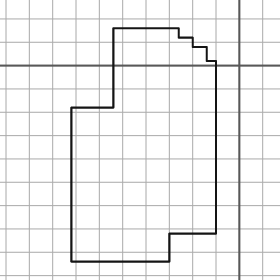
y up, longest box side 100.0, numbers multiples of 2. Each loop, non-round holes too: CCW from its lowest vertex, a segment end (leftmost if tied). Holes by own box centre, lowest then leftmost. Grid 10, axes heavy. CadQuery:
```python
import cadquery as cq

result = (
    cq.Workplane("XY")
    .moveTo(-72.0, -84.0)
    .lineTo(-30.0, -84.0)
    .lineTo(-30.0, -72.0)
    .lineTo(-10.0, -72.0)
    .lineTo(-10.0, 2.0)
    .lineTo(-14.0, 2.0)
    .lineTo(-14.0, 8.0)
    .lineTo(-20.0, 8.0)
    .lineTo(-20.0, 12.0)
    .lineTo(-26.0, 12.0)
    .lineTo(-26.0, 16.0)
    .lineTo(-54.0, 16.0)
    .lineTo(-54.0, -18.0)
    .lineTo(-72.0, -18.0)
    .close()
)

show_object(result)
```